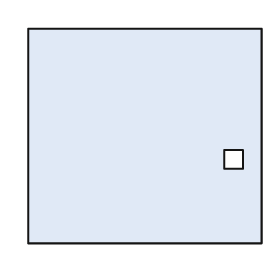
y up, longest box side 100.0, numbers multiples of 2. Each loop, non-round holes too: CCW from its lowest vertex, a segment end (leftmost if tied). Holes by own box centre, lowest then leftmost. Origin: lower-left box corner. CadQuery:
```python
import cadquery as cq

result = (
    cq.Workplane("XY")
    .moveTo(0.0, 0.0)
    .lineTo(100.0, 0.0)
    .lineTo(100.0, 92.0)
    .lineTo(0.0, 92.0)
    .close()
    .moveTo(84.0, 32.0)
    .lineTo(92.0, 32.0)
    .lineTo(92.0, 40.0)
    .lineTo(84.0, 40.0)
    .close()
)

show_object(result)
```